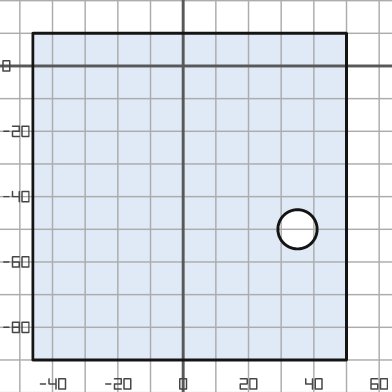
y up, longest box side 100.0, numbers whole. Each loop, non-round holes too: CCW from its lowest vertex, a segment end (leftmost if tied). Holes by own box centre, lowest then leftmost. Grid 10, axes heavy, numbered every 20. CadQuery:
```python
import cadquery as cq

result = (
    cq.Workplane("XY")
    .moveTo(-46.0, -90.0)
    .lineTo(50.0, -90.0)
    .lineTo(50.0, 10.0)
    .lineTo(-46.0, 10.0)
    .close()
    .moveTo(35.0, -50.0)
    .circle(6.0)
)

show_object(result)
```